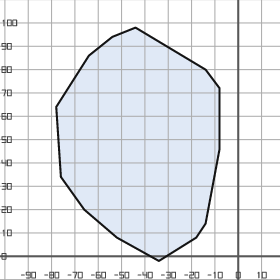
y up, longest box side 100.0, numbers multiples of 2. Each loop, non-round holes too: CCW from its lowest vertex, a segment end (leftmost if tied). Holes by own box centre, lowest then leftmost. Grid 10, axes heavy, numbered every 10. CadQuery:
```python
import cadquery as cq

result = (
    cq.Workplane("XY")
    .moveTo(-34.0, -2.0)
    .lineTo(-18.0, 8.0)
    .lineTo(-14.0, 14.0)
    .lineTo(-8.0, 46.0)
    .lineTo(-8.0, 72.0)
    .lineTo(-14.0, 80.0)
    .lineTo(-44.0, 98.0)
    .lineTo(-54.0, 94.0)
    .lineTo(-64.0, 86.0)
    .lineTo(-78.0, 64.0)
    .lineTo(-76.0, 34.0)
    .lineTo(-66.0, 20.0)
    .lineTo(-52.0, 8.0)
    .close()
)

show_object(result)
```